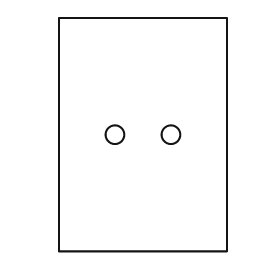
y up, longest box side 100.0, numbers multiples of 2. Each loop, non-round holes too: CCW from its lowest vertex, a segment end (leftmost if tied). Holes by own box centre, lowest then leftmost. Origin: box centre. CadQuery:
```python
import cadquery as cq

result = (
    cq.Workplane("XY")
    .moveTo(-36.0, -50.0)
    .lineTo(36.0, -50.0)
    .lineTo(36.0, 50.0)
    .lineTo(-36.0, 50.0)
    .close()
    .moveTo(-12.0, 0.0)
    .circle(4.0)
    .moveTo(12.0, 0.0)
    .circle(4.0)
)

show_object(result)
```